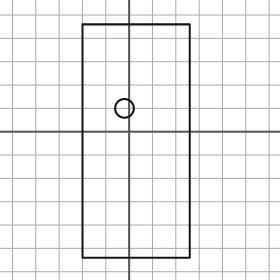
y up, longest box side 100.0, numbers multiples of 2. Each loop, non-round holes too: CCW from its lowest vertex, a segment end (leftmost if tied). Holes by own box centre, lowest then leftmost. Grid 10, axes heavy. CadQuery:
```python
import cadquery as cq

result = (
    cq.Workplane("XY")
    .moveTo(-20.0, -54.0)
    .lineTo(26.0, -54.0)
    .lineTo(26.0, 46.0)
    .lineTo(-20.0, 46.0)
    .close()
    .moveTo(-2.0, 10.0)
    .circle(4.0)
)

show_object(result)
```